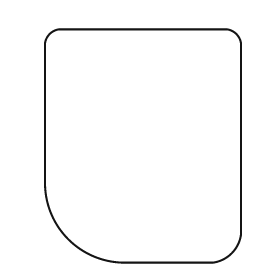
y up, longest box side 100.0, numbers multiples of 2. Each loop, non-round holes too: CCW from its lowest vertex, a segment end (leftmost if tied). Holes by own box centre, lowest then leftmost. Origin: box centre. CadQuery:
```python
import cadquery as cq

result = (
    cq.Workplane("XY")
    .moveTo(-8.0, -50.0)
    .lineTo(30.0, -50.0)
    .threePointArc((38.0, -46.0), (42.0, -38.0))
    .lineTo(42.0, 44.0)
    .threePointArc((40.0, 48.0), (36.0, 50.0))
    .lineTo(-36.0, 50.0)
    .threePointArc((-40.0, 48.0), (-42.0, 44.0))
    .lineTo(-42.0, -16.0)
    .threePointArc((-32.0, -40.0), (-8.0, -50.0))
    .close()
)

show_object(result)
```